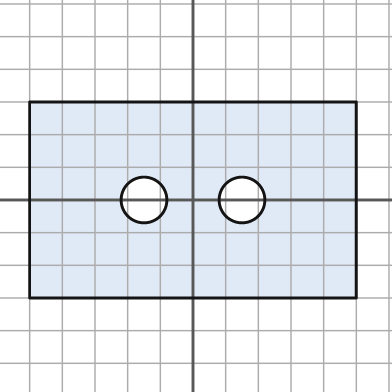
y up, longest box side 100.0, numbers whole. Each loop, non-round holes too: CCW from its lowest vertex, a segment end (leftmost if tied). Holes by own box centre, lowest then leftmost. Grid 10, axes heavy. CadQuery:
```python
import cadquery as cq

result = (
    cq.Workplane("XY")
    .moveTo(-50.0, -30.0)
    .lineTo(50.0, -30.0)
    .lineTo(50.0, 30.0)
    .lineTo(-50.0, 30.0)
    .close()
    .moveTo(-15.0, 0.0)
    .circle(7.0)
    .moveTo(15.0, 0.0)
    .circle(7.0)
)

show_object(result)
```